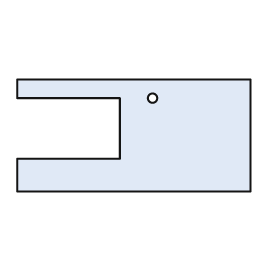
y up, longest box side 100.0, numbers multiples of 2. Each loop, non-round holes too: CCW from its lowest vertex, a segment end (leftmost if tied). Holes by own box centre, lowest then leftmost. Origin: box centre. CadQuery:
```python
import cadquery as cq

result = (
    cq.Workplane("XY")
    .moveTo(-50.0, -24.0)
    .lineTo(50.0, -24.0)
    .lineTo(50.0, 24.0)
    .lineTo(-50.0, 24.0)
    .lineTo(-50.0, 16.0)
    .lineTo(-6.0, 16.0)
    .lineTo(-6.0, -10.0)
    .lineTo(-50.0, -10.0)
    .close()
    .moveTo(8.0, 16.0)
    .circle(2.0)
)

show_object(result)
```